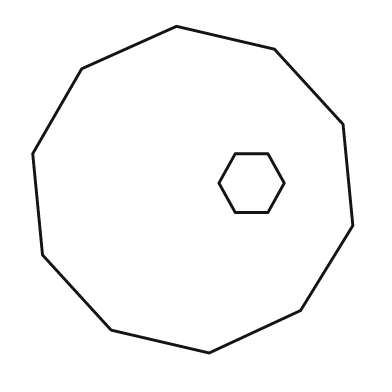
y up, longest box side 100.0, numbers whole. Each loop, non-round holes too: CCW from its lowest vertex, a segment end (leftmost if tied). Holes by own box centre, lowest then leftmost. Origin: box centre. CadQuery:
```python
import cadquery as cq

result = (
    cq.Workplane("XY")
    .moveTo(5.0, -50.0)
    .lineTo(33.0, -37.0)
    .lineTo(49.0, -11.0)
    .lineTo(46.0, 20.0)
    .lineTo(25.0, 43.0)
    .lineTo(-5.0, 50.0)
    .lineTo(-34.0, 37.0)
    .lineTo(-49.0, 11.0)
    .lineTo(-46.0, -20.0)
    .lineTo(-25.0, -43.0)
    .close()
    .moveTo(13.0, -7.0)
    .lineTo(23.0, -7.0)
    .lineTo(28.0, 2.0)
    .lineTo(23.0, 11.0)
    .lineTo(13.0, 11.0)
    .lineTo(8.0, 2.0)
    .close()
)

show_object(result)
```